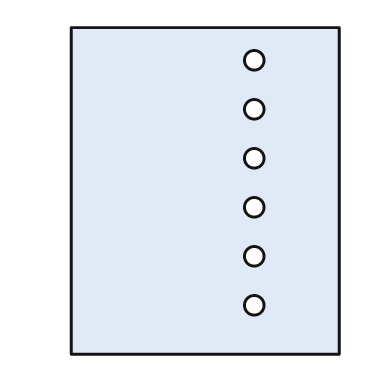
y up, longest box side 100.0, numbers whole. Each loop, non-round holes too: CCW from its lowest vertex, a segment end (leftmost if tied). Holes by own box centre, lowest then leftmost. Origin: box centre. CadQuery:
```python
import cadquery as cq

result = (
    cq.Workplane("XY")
    .moveTo(-41.0, -50.0)
    .lineTo(41.0, -50.0)
    .lineTo(41.0, 50.0)
    .lineTo(-41.0, 50.0)
    .close()
    .moveTo(15.0, -35.0)
    .circle(3.0)
    .moveTo(15.0, -20.0)
    .circle(3.0)
    .moveTo(15.0, -5.0)
    .circle(3.0)
    .moveTo(15.0, 10.0)
    .circle(3.0)
    .moveTo(15.0, 25.0)
    .circle(3.0)
    .moveTo(15.0, 40.0)
    .circle(3.0)
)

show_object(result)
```